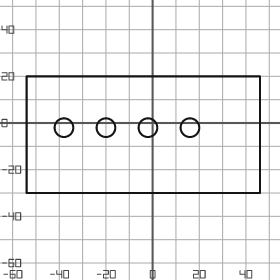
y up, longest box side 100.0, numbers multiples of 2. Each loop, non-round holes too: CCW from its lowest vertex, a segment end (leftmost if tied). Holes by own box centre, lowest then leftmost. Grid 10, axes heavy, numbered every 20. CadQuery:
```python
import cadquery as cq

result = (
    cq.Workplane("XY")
    .moveTo(-54.0, -30.0)
    .lineTo(46.0, -30.0)
    .lineTo(46.0, 20.0)
    .lineTo(-54.0, 20.0)
    .close()
    .moveTo(-38.0, -2.0)
    .circle(4.0)
    .moveTo(-20.0, -2.0)
    .circle(4.0)
    .moveTo(-2.0, -2.0)
    .circle(4.0)
    .moveTo(16.0, -2.0)
    .circle(4.0)
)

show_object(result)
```